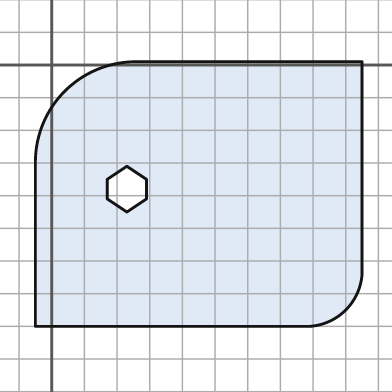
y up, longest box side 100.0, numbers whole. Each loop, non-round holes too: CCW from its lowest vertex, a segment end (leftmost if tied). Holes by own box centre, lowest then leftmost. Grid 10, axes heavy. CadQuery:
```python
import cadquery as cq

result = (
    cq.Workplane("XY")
    .moveTo(-5.0, -80.0)
    .lineTo(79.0, -80.0)
    .threePointArc((90.0, -75.0), (95.0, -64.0))
    .lineTo(95.0, 1.0)
    .lineTo(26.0, 1.0)
    .threePointArc((4.0, -8.0), (-5.0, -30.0))
    .close()
    .moveTo(23.0, -45.0)
    .lineTo(29.0, -41.0)
    .lineTo(29.0, -35.0)
    .lineTo(23.0, -31.0)
    .lineTo(17.0, -35.0)
    .lineTo(17.0, -41.0)
    .close()
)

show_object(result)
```